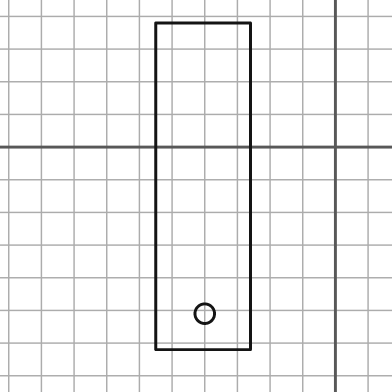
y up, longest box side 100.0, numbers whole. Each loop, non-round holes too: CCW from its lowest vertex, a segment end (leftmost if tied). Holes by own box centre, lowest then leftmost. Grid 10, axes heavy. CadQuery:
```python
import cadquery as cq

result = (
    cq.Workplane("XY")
    .moveTo(-55.0, -62.0)
    .lineTo(-26.0, -62.0)
    .lineTo(-26.0, 38.0)
    .lineTo(-55.0, 38.0)
    .close()
    .moveTo(-40.0, -51.0)
    .circle(3.0)
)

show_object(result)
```